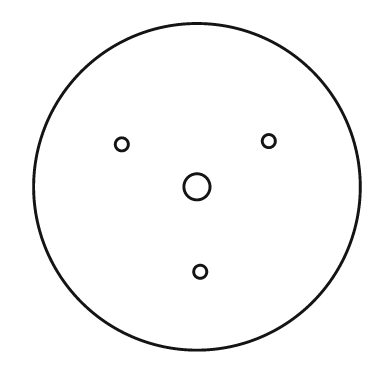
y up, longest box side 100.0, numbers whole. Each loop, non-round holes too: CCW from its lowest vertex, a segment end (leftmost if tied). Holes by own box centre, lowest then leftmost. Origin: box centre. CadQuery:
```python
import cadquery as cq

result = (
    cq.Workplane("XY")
    .moveTo(0.0, 0.0)
    .circle(50.0)
    .moveTo(1.0, -26.0)
    .circle(2.0)
    .moveTo(0.0, 0.0)
    .circle(4.0)
    .moveTo(-23.0, 13.0)
    .circle(2.0)
    .moveTo(22.0, 14.0)
    .circle(2.0)
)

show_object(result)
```